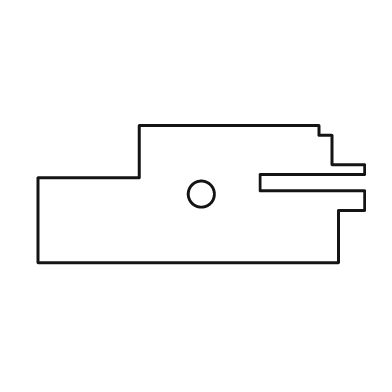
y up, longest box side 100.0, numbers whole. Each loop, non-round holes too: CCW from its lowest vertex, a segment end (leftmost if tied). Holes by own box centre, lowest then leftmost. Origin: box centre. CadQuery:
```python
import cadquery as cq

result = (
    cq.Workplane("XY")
    .moveTo(-50.0, -21.0)
    .lineTo(42.0, -21.0)
    .lineTo(42.0, -5.0)
    .lineTo(50.0, -5.0)
    .lineTo(50.0, 1.0)
    .lineTo(18.0, 1.0)
    .lineTo(18.0, 6.0)
    .lineTo(50.0, 6.0)
    .lineTo(50.0, 9.0)
    .lineTo(40.0, 9.0)
    .lineTo(40.0, 18.0)
    .lineTo(36.0, 18.0)
    .lineTo(36.0, 21.0)
    .lineTo(-19.0, 21.0)
    .lineTo(-19.0, 5.0)
    .lineTo(-50.0, 5.0)
    .close()
    .moveTo(0.0, 0.0)
    .circle(4.0)
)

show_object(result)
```